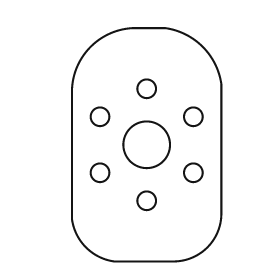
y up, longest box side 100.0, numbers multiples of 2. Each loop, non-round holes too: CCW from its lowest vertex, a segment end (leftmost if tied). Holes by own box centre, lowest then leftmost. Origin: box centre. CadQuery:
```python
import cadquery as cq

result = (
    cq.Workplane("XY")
    .moveTo(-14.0, -50.0)
    .lineTo(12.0, -50.0)
    .threePointArc((26.0, -44.0), (32.0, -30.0))
    .lineTo(32.0, 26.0)
    .threePointArc((24.0, 42.0), (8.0, 50.0))
    .lineTo(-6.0, 50.0)
    .threePointArc((-24.0, 42.0), (-32.0, 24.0))
    .lineTo(-32.0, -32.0)
    .threePointArc((-26.0, -44.0), (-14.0, -50.0))
    .close()
    .moveTo(0.0, -24.0)
    .circle(4.0)
    .moveTo(-20.0, -12.0)
    .circle(4.0)
    .moveTo(20.0, -12.0)
    .circle(4.0)
    .moveTo(0.0, 0.0)
    .circle(10.0)
    .moveTo(-20.0, 12.0)
    .circle(4.0)
    .moveTo(20.0, 12.0)
    .circle(4.0)
    .moveTo(0.0, 24.0)
    .circle(4.0)
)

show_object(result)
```